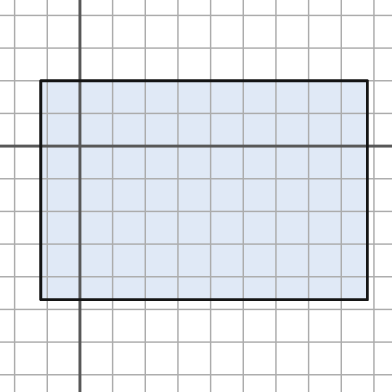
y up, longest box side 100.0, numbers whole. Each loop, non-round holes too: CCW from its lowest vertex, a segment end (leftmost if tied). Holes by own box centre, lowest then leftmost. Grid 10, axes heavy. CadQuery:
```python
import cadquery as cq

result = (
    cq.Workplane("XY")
    .moveTo(-12.0, -47.0)
    .lineTo(88.0, -47.0)
    .lineTo(88.0, 20.0)
    .lineTo(-12.0, 20.0)
    .close()
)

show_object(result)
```